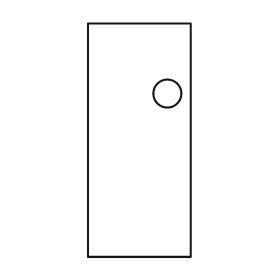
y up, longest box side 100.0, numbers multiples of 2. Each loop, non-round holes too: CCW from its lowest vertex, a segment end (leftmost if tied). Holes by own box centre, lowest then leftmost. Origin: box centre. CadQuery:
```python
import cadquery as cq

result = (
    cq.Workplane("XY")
    .moveTo(-22.0, -50.0)
    .lineTo(22.0, -50.0)
    .lineTo(22.0, 50.0)
    .lineTo(-22.0, 50.0)
    .close()
    .moveTo(12.0, 20.0)
    .circle(6.0)
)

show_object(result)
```